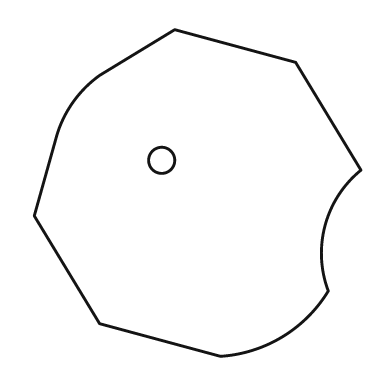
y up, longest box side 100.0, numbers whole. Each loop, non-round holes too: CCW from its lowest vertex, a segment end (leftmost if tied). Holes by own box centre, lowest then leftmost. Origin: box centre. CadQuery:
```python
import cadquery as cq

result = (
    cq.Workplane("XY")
    .moveTo(7.0, -50.0)
    .threePointArc((26.0, -44.0), (40.0, -30.0))
    .threePointArc((39.0, -10.0), (50.0, 7.0))
    .lineTo(30.0, 40.0)
    .lineTo(-7.0, 50.0)
    .lineTo(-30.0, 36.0)
    .threePointArc((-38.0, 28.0), (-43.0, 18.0))
    .lineTo(-50.0, -7.0)
    .lineTo(-30.0, -40.0)
    .close()
    .moveTo(-11.0, 10.0)
    .circle(4.0)
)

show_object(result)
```